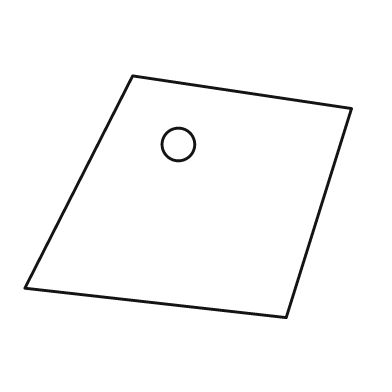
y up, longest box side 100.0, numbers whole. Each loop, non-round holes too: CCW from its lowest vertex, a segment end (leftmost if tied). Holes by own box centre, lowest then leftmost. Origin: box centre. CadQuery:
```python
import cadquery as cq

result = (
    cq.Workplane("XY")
    .moveTo(30.0, -37.0)
    .lineTo(50.0, 27.0)
    .lineTo(-17.0, 37.0)
    .lineTo(-50.0, -28.0)
    .close()
    .moveTo(-3.0, 16.0)
    .circle(5.0)
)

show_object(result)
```